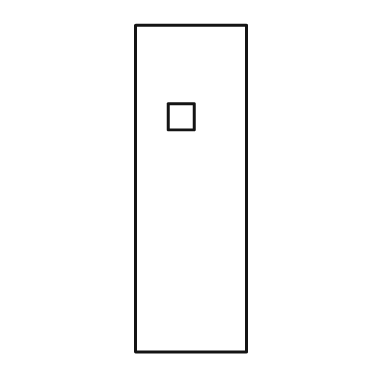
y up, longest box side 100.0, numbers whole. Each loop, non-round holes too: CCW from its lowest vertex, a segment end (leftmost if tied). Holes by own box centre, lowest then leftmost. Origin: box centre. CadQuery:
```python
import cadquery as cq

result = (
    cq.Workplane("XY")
    .moveTo(-17.0, -50.0)
    .lineTo(17.0, -50.0)
    .lineTo(17.0, 50.0)
    .lineTo(-17.0, 50.0)
    .close()
    .moveTo(-7.0, 18.0)
    .lineTo(1.0, 18.0)
    .lineTo(1.0, 26.0)
    .lineTo(-7.0, 26.0)
    .close()
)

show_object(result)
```